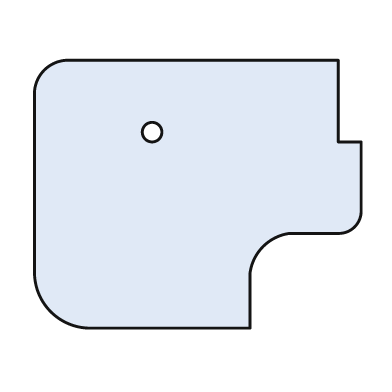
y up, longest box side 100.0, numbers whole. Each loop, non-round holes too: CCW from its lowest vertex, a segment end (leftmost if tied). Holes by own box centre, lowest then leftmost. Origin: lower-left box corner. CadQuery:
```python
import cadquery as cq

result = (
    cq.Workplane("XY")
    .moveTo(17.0, 0.0)
    .lineTo(66.0, 0.0)
    .lineTo(66.0, 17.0)
    .threePointArc((70.0, 25.0), (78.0, 29.0))
    .lineTo(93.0, 29.0)
    .threePointArc((98.0, 31.0), (100.0, 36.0))
    .lineTo(100.0, 57.0)
    .lineTo(93.0, 57.0)
    .lineTo(93.0, 82.0)
    .lineTo(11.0, 82.0)
    .threePointArc((3.0, 79.0), (0.0, 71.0))
    .lineTo(0.0, 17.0)
    .threePointArc((5.0, 5.0), (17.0, 0.0))
    .close()
    .moveTo(36.0, 60.0)
    .circle(3.0)
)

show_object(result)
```